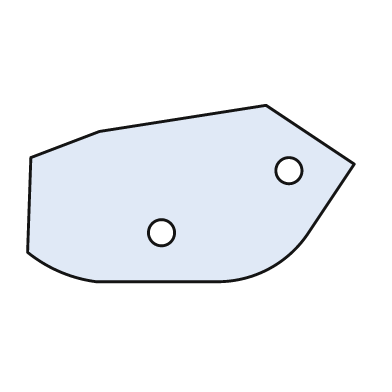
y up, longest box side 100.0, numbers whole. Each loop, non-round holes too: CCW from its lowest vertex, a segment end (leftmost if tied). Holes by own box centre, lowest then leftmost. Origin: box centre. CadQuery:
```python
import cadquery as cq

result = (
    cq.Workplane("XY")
    .moveTo(-29.0, -27.0)
    .lineTo(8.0, -27.0)
    .threePointArc((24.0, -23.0), (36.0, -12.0))
    .lineTo(50.0, 9.0)
    .lineTo(23.0, 27.0)
    .lineTo(-28.0, 19.0)
    .lineTo(-49.0, 11.0)
    .lineTo(-50.0, -18.0)
    .threePointArc((-40.0, -24.0), (-29.0, -27.0))
    .close()
    .moveTo(-9.0, -12.0)
    .circle(4.0)
    .moveTo(30.0, 7.0)
    .circle(4.0)
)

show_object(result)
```